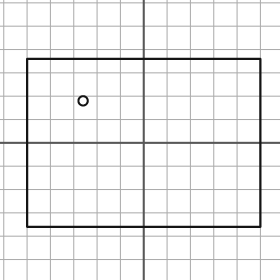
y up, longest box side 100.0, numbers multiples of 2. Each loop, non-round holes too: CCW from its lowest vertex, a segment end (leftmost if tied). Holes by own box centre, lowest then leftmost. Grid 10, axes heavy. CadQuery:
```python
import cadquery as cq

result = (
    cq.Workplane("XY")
    .moveTo(-50.0, -36.0)
    .lineTo(50.0, -36.0)
    .lineTo(50.0, 36.0)
    .lineTo(-50.0, 36.0)
    .close()
    .moveTo(-26.0, 18.0)
    .circle(2.0)
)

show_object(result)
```